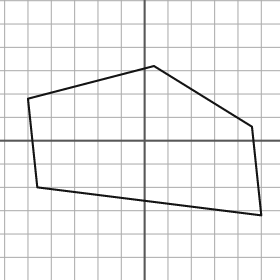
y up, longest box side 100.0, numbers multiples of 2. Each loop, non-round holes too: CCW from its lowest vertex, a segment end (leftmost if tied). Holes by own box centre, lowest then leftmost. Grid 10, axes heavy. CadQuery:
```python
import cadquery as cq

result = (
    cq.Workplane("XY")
    .moveTo(50.0, -32.0)
    .lineTo(46.0, 6.0)
    .lineTo(4.0, 32.0)
    .lineTo(-50.0, 18.0)
    .lineTo(-46.0, -20.0)
    .close()
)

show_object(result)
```